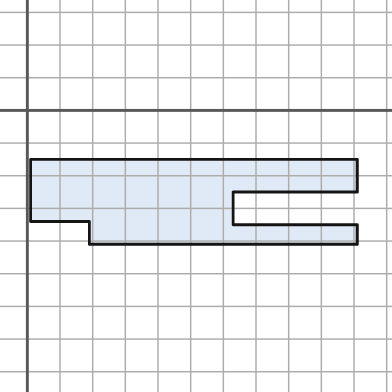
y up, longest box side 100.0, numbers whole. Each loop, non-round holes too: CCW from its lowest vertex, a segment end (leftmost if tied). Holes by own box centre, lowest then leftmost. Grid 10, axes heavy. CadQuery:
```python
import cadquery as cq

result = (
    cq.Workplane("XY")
    .moveTo(19.0, -41.0)
    .lineTo(101.0, -41.0)
    .lineTo(101.0, -35.0)
    .lineTo(63.0, -35.0)
    .lineTo(63.0, -25.0)
    .lineTo(101.0, -25.0)
    .lineTo(101.0, -15.0)
    .lineTo(1.0, -15.0)
    .lineTo(1.0, -34.0)
    .lineTo(19.0, -34.0)
    .close()
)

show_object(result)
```